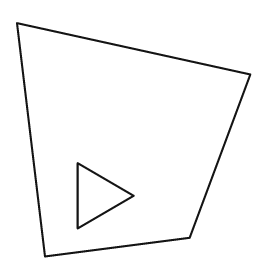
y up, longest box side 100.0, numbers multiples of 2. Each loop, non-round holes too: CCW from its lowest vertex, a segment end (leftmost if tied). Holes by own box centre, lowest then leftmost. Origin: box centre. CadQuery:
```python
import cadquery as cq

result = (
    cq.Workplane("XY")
    .moveTo(-38.0, -50.0)
    .lineTo(24.0, -42.0)
    .lineTo(50.0, 28.0)
    .lineTo(-50.0, 50.0)
    .close()
    .moveTo(-24.0, -38.0)
    .lineTo(0.0, -24.0)
    .lineTo(-24.0, -10.0)
    .close()
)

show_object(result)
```